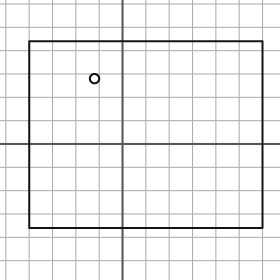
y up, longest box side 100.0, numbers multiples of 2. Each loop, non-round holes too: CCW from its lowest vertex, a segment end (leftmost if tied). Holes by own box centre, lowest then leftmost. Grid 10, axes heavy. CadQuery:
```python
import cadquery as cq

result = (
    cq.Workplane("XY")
    .moveTo(-40.0, -36.0)
    .lineTo(60.0, -36.0)
    .lineTo(60.0, 44.0)
    .lineTo(-40.0, 44.0)
    .close()
    .moveTo(-12.0, 28.0)
    .circle(2.0)
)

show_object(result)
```